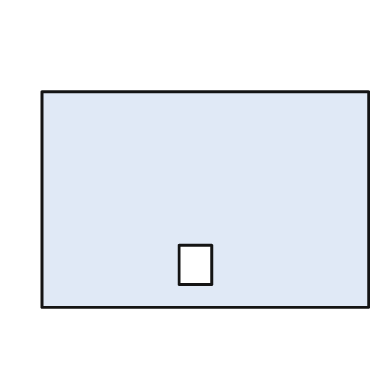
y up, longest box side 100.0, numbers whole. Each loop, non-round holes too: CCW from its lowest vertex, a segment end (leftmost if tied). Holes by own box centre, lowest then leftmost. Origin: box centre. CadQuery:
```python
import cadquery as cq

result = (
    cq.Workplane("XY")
    .moveTo(-50.0, -33.0)
    .lineTo(50.0, -33.0)
    .lineTo(50.0, 33.0)
    .lineTo(-50.0, 33.0)
    .close()
    .moveTo(-8.0, -26.0)
    .lineTo(2.0, -26.0)
    .lineTo(2.0, -14.0)
    .lineTo(-8.0, -14.0)
    .close()
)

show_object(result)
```